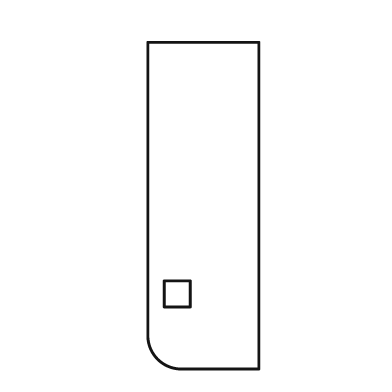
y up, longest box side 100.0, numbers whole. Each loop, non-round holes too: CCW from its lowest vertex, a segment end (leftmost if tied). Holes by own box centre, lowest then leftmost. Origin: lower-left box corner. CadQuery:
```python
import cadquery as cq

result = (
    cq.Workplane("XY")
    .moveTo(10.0, 0.0)
    .lineTo(34.0, 0.0)
    .lineTo(34.0, 100.0)
    .lineTo(0.0, 100.0)
    .lineTo(0.0, 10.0)
    .threePointArc((3.0, 3.0), (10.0, 0.0))
    .close()
    .moveTo(5.0, 19.0)
    .lineTo(13.0, 19.0)
    .lineTo(13.0, 27.0)
    .lineTo(5.0, 27.0)
    .close()
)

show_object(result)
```